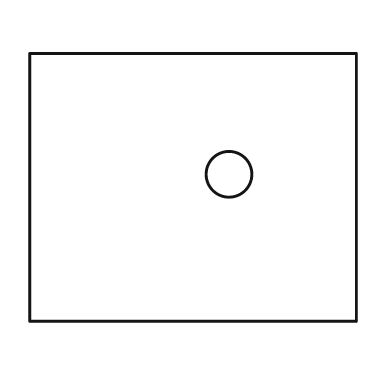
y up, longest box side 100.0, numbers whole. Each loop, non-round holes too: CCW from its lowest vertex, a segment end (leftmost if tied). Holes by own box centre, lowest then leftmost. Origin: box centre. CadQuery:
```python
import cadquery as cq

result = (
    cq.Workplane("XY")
    .moveTo(-50.0, -41.0)
    .lineTo(50.0, -41.0)
    .lineTo(50.0, 41.0)
    .lineTo(-50.0, 41.0)
    .close()
    .moveTo(11.0, 4.0)
    .circle(7.0)
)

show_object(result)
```